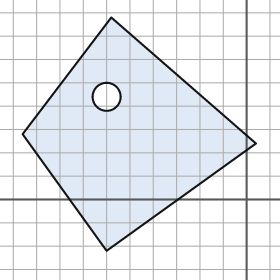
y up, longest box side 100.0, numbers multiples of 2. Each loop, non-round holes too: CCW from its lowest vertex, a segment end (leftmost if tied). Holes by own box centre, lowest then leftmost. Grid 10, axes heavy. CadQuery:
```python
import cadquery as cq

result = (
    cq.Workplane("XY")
    .moveTo(-60.0, -22.0)
    .lineTo(4.0, 24.0)
    .lineTo(-58.0, 78.0)
    .lineTo(-96.0, 28.0)
    .close()
    .moveTo(-60.0, 44.0)
    .circle(6.0)
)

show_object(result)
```